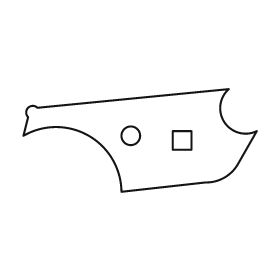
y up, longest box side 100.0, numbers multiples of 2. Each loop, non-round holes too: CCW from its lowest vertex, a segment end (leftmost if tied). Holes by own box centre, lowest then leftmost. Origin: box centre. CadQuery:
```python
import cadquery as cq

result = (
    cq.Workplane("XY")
    .moveTo(-8.0, -22.0)
    .lineTo(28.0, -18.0)
    .threePointArc((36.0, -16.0), (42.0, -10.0))
    .lineTo(50.0, 4.0)
    .threePointArc((36.0, 8.0), (38.0, 22.0))
    .lineTo(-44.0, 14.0)
    .threePointArc((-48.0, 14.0), (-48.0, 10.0))
    .lineTo(-50.0, 2.0)
    .threePointArc((-22.0, 2.0), (-8.0, -22.0))
    .close()
    .moveTo(14.0, -4.0)
    .lineTo(22.0, -4.0)
    .lineTo(22.0, 4.0)
    .lineTo(14.0, 4.0)
    .close()
    .moveTo(-4.0, 2.0)
    .circle(4.0)
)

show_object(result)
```